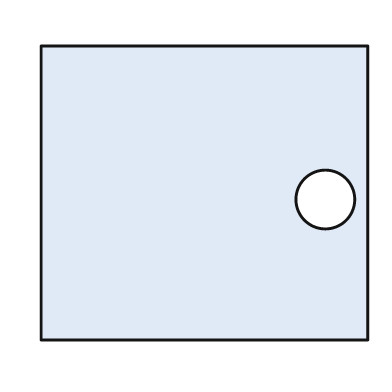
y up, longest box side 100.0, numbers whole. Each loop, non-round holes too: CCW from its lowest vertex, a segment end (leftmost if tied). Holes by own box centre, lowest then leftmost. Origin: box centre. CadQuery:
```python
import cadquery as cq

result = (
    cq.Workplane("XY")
    .moveTo(-50.0, -45.0)
    .lineTo(50.0, -45.0)
    .lineTo(50.0, 45.0)
    .lineTo(-50.0, 45.0)
    .close()
    .moveTo(37.0, -2.0)
    .circle(9.0)
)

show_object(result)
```